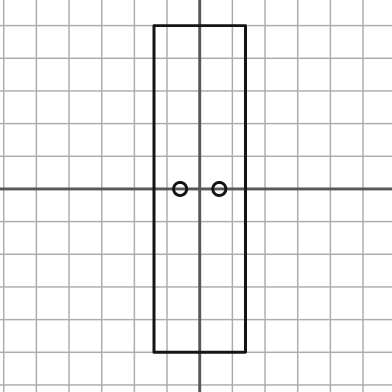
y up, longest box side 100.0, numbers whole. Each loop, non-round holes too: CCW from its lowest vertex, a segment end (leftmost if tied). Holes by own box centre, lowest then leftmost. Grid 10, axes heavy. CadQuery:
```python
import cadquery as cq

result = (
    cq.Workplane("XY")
    .moveTo(-14.0, -50.0)
    .lineTo(14.0, -50.0)
    .lineTo(14.0, 50.0)
    .lineTo(-14.0, 50.0)
    .close()
    .moveTo(-6.0, 0.0)
    .circle(2.0)
    .moveTo(6.0, 0.0)
    .circle(2.0)
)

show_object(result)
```